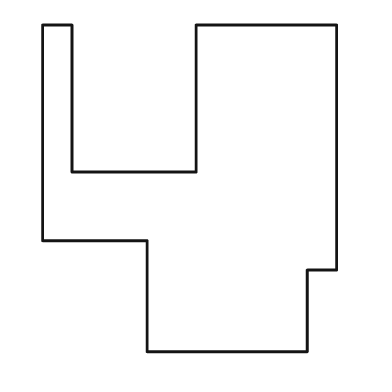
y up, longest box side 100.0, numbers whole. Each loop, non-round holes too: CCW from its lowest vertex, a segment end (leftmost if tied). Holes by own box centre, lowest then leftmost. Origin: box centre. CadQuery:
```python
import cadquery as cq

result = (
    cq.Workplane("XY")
    .moveTo(-13.0, -50.0)
    .lineTo(36.0, -50.0)
    .lineTo(36.0, -25.0)
    .lineTo(45.0, -25.0)
    .lineTo(45.0, 50.0)
    .lineTo(2.0, 50.0)
    .lineTo(2.0, 5.0)
    .lineTo(-36.0, 5.0)
    .lineTo(-36.0, 50.0)
    .lineTo(-45.0, 50.0)
    .lineTo(-45.0, -16.0)
    .lineTo(-13.0, -16.0)
    .close()
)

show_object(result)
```